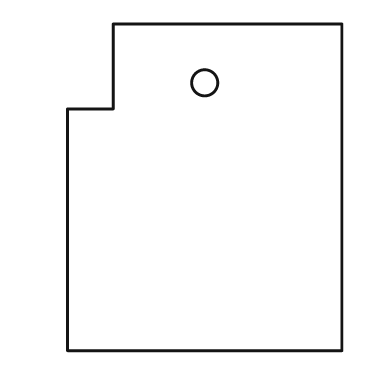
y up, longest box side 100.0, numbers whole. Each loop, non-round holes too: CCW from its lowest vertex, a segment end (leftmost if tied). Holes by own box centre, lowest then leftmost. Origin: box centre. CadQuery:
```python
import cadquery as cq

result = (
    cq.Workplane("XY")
    .moveTo(-42.0, -50.0)
    .lineTo(42.0, -50.0)
    .lineTo(42.0, 50.0)
    .lineTo(-28.0, 50.0)
    .lineTo(-28.0, 24.0)
    .lineTo(-42.0, 24.0)
    .close()
    .moveTo(0.0, 32.0)
    .circle(4.0)
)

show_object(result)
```